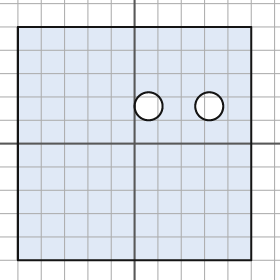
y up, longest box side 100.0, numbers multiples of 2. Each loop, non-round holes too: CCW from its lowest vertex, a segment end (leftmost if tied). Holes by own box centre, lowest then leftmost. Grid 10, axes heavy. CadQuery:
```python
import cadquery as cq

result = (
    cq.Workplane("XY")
    .moveTo(-50.0, -50.0)
    .lineTo(50.0, -50.0)
    .lineTo(50.0, 50.0)
    .lineTo(-50.0, 50.0)
    .close()
    .moveTo(6.0, 16.0)
    .circle(6.0)
    .moveTo(32.0, 16.0)
    .circle(6.0)
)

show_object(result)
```